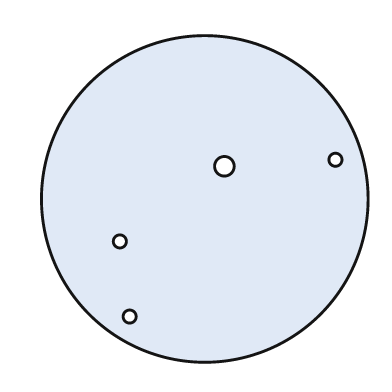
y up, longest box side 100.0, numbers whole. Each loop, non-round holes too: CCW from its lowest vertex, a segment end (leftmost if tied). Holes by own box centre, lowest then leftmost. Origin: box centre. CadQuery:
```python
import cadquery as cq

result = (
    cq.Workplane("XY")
    .moveTo(0.0, 0.0)
    .circle(50.0)
    .moveTo(-23.0, -36.0)
    .circle(2.0)
    .moveTo(-26.0, -13.0)
    .circle(2.0)
    .moveTo(6.0, 10.0)
    .circle(3.0)
    .moveTo(40.0, 12.0)
    .circle(2.0)
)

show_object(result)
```